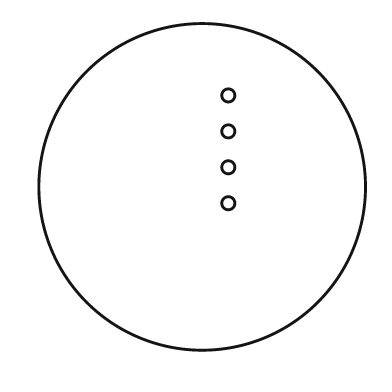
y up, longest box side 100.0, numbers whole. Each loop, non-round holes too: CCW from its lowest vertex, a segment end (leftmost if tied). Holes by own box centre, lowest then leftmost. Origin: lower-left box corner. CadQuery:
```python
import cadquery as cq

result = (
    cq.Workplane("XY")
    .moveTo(50.0, 50.0)
    .circle(50.0)
    .moveTo(58.0, 45.0)
    .circle(2.0)
    .moveTo(58.0, 56.0)
    .circle(2.0)
    .moveTo(58.0, 67.0)
    .circle(2.0)
    .moveTo(58.0, 78.0)
    .circle(2.0)
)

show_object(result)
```